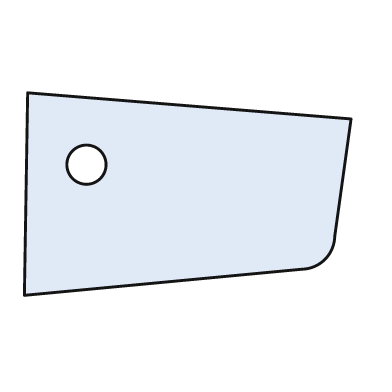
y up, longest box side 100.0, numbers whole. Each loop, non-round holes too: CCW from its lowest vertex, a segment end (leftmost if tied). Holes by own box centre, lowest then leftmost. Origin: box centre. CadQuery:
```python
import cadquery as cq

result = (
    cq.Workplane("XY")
    .moveTo(-50.0, -31.0)
    .lineTo(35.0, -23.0)
    .threePointArc((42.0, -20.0), (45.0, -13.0))
    .lineTo(50.0, 23.0)
    .lineTo(-49.0, 31.0)
    .close()
    .moveTo(-31.0, 9.0)
    .circle(6.0)
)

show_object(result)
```